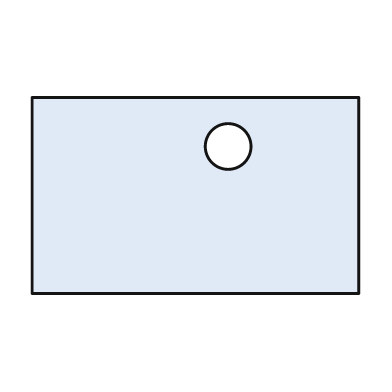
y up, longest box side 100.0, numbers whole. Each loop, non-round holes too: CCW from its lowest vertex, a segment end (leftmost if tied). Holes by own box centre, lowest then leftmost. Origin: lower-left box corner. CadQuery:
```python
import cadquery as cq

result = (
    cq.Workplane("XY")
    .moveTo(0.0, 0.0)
    .lineTo(100.0, 0.0)
    .lineTo(100.0, 60.0)
    .lineTo(0.0, 60.0)
    .close()
    .moveTo(60.0, 45.0)
    .circle(7.0)
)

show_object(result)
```